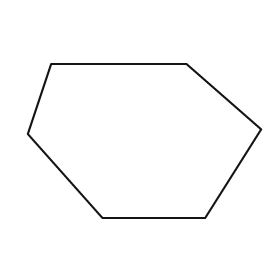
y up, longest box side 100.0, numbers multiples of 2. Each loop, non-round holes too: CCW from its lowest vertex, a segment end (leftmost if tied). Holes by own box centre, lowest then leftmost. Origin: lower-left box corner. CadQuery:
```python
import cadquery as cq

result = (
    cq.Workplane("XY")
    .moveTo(32.0, 0.0)
    .lineTo(76.0, 0.0)
    .lineTo(100.0, 38.0)
    .lineTo(68.0, 66.0)
    .lineTo(10.0, 66.0)
    .lineTo(0.0, 36.0)
    .close()
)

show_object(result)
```